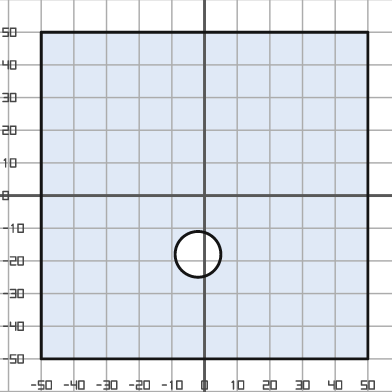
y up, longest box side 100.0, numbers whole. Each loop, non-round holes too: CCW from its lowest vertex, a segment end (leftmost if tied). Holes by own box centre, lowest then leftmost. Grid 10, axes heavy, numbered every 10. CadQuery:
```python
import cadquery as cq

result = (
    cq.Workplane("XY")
    .moveTo(-50.0, -50.0)
    .lineTo(50.0, -50.0)
    .lineTo(50.0, 50.0)
    .lineTo(-50.0, 50.0)
    .close()
    .moveTo(-2.0, -18.0)
    .circle(7.0)
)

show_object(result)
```